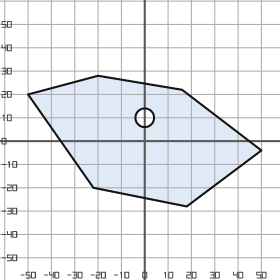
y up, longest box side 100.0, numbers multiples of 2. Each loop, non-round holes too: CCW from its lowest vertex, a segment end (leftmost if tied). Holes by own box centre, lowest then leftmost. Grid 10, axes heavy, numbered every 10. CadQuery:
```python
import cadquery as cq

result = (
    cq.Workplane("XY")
    .moveTo(18.0, -28.0)
    .lineTo(50.0, -4.0)
    .lineTo(16.0, 22.0)
    .lineTo(-20.0, 28.0)
    .lineTo(-50.0, 20.0)
    .lineTo(-22.0, -20.0)
    .close()
    .moveTo(0.0, 10.0)
    .circle(4.0)
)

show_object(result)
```